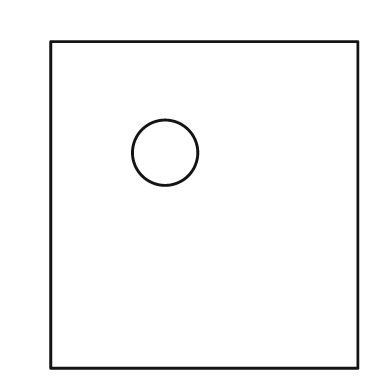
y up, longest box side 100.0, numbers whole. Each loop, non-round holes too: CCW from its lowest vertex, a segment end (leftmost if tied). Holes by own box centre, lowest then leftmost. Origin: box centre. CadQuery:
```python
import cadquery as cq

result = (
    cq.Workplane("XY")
    .moveTo(-47.0, -50.0)
    .lineTo(47.0, -50.0)
    .lineTo(47.0, 50.0)
    .lineTo(-47.0, 50.0)
    .close()
    .moveTo(-12.0, 16.0)
    .circle(10.0)
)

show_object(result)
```